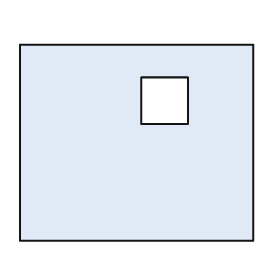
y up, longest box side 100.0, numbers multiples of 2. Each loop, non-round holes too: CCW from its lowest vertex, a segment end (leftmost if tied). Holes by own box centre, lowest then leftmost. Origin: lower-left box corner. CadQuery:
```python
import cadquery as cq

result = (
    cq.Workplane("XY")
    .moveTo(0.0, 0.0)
    .lineTo(100.0, 0.0)
    .lineTo(100.0, 84.0)
    .lineTo(0.0, 84.0)
    .close()
    .moveTo(52.0, 50.0)
    .lineTo(72.0, 50.0)
    .lineTo(72.0, 70.0)
    .lineTo(52.0, 70.0)
    .close()
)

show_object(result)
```